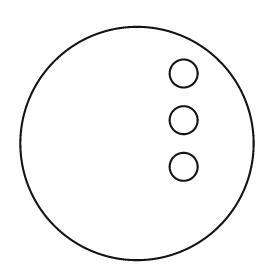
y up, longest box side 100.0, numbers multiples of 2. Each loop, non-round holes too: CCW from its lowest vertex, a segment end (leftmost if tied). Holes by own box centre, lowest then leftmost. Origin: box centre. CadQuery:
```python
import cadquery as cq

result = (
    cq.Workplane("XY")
    .moveTo(0.0, 0.0)
    .circle(50.0)
    .moveTo(20.0, -10.0)
    .circle(6.0)
    .moveTo(20.0, 10.0)
    .circle(6.0)
    .moveTo(20.0, 30.0)
    .circle(6.0)
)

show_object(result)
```